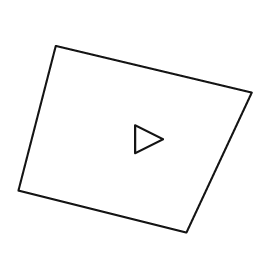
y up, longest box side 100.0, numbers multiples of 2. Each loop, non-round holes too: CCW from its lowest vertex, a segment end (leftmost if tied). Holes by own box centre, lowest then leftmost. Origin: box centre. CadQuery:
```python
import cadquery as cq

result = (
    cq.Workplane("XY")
    .moveTo(22.0, -40.0)
    .lineTo(50.0, 20.0)
    .lineTo(-34.0, 40.0)
    .lineTo(-50.0, -22.0)
    .close()
    .moveTo(0.0, -6.0)
    .lineTo(12.0, 0.0)
    .lineTo(0.0, 6.0)
    .close()
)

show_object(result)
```